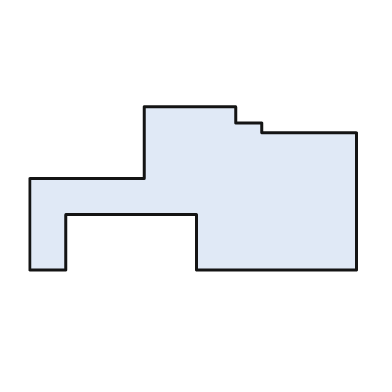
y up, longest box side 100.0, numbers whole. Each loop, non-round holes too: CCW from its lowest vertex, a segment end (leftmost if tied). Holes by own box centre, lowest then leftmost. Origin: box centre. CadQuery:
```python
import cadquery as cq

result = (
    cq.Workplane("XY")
    .moveTo(-50.0, -25.0)
    .lineTo(-39.0, -25.0)
    .lineTo(-39.0, -8.0)
    .lineTo(1.0, -8.0)
    .lineTo(1.0, -25.0)
    .lineTo(50.0, -25.0)
    .lineTo(50.0, 17.0)
    .lineTo(21.0, 17.0)
    .lineTo(21.0, 20.0)
    .lineTo(13.0, 20.0)
    .lineTo(13.0, 25.0)
    .lineTo(-15.0, 25.0)
    .lineTo(-15.0, 3.0)
    .lineTo(-50.0, 3.0)
    .close()
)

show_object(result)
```